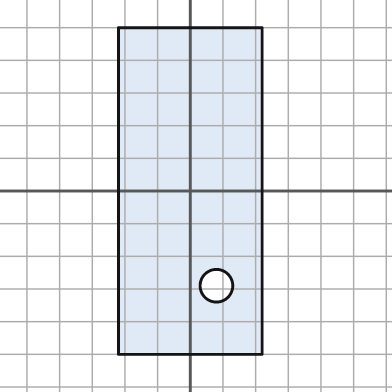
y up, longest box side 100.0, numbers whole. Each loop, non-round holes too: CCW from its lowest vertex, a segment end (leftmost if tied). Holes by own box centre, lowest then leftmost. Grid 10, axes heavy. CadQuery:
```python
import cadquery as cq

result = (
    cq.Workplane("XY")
    .moveTo(-22.0, -50.0)
    .lineTo(22.0, -50.0)
    .lineTo(22.0, 50.0)
    .lineTo(-22.0, 50.0)
    .close()
    .moveTo(8.0, -29.0)
    .circle(5.0)
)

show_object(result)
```